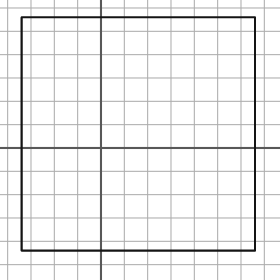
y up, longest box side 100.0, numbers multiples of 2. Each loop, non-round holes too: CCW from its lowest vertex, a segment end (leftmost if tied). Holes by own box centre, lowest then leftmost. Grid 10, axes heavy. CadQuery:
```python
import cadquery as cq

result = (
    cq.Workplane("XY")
    .moveTo(-34.0, -44.0)
    .lineTo(66.0, -44.0)
    .lineTo(66.0, 56.0)
    .lineTo(-34.0, 56.0)
    .close()
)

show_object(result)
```